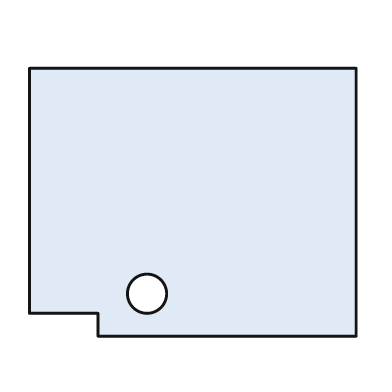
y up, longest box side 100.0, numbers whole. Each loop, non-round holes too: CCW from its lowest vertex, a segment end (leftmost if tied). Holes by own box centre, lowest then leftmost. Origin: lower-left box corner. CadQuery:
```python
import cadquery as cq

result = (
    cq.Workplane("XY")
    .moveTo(21.0, 0.0)
    .lineTo(100.0, 0.0)
    .lineTo(100.0, 82.0)
    .lineTo(0.0, 82.0)
    .lineTo(0.0, 7.0)
    .lineTo(21.0, 7.0)
    .close()
    .moveTo(36.0, 13.0)
    .circle(6.0)
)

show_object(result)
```